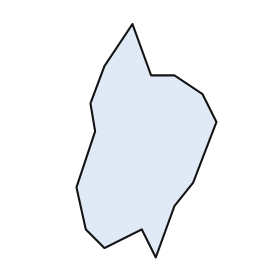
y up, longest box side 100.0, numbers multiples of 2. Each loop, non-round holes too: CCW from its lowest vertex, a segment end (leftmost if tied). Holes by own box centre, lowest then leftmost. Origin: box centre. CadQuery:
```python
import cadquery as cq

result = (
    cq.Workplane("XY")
    .moveTo(4.0, -50.0)
    .lineTo(12.0, -28.0)
    .lineTo(20.0, -18.0)
    .lineTo(30.0, 8.0)
    .lineTo(24.0, 20.0)
    .lineTo(12.0, 28.0)
    .lineTo(2.0, 28.0)
    .lineTo(-6.0, 50.0)
    .lineTo(-18.0, 32.0)
    .lineTo(-24.0, 16.0)
    .lineTo(-22.0, 4.0)
    .lineTo(-30.0, -20.0)
    .lineTo(-26.0, -38.0)
    .lineTo(-18.0, -46.0)
    .lineTo(-2.0, -38.0)
    .close()
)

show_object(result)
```